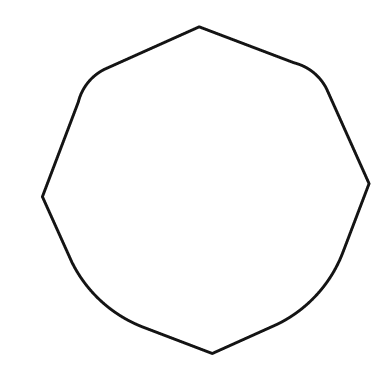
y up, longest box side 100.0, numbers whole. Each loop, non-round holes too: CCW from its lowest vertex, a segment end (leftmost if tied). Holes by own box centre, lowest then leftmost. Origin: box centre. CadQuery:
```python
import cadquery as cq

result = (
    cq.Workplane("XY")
    .moveTo(2.0, -50.0)
    .lineTo(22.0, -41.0)
    .threePointArc((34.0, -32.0), (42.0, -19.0))
    .lineTo(50.0, 2.0)
    .lineTo(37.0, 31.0)
    .threePointArc((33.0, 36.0), (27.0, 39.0))
    .lineTo(-2.0, 50.0)
    .lineTo(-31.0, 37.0)
    .threePointArc((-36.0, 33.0), (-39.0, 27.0))
    .lineTo(-50.0, -2.0)
    .lineTo(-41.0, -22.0)
    .threePointArc((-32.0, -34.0), (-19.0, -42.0))
    .close()
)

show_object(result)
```